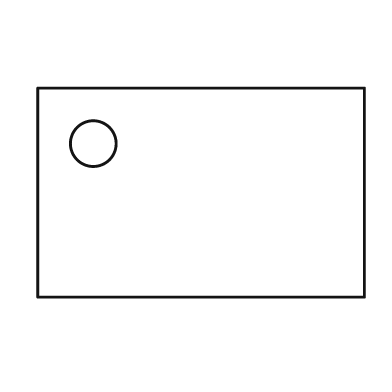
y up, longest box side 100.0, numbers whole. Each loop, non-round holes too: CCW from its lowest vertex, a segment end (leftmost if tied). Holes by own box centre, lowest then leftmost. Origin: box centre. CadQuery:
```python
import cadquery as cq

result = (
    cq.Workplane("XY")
    .moveTo(-50.0, -32.0)
    .lineTo(50.0, -32.0)
    .lineTo(50.0, 32.0)
    .lineTo(-50.0, 32.0)
    .close()
    .moveTo(-33.0, 15.0)
    .circle(7.0)
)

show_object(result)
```